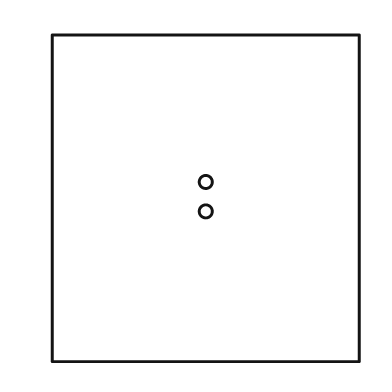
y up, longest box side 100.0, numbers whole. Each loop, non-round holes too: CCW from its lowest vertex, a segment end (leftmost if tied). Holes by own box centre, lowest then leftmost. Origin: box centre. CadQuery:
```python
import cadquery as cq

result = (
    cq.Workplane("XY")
    .moveTo(-47.0, -50.0)
    .lineTo(47.0, -50.0)
    .lineTo(47.0, 50.0)
    .lineTo(-47.0, 50.0)
    .close()
    .moveTo(0.0, -4.0)
    .circle(2.0)
    .moveTo(0.0, 5.0)
    .circle(2.0)
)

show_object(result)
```